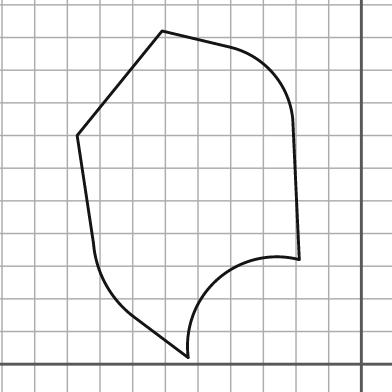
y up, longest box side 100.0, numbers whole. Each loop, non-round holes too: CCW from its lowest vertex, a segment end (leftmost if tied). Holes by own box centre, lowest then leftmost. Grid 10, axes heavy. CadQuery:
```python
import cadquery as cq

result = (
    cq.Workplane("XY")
    .moveTo(-53.0, 2.0)
    .threePointArc((-44.0, 26.0), (-19.0, 32.0))
    .lineTo(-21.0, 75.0)
    .threePointArc((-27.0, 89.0), (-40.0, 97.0))
    .lineTo(-61.0, 102.0)
    .lineTo(-87.0, 70.0)
    .lineTo(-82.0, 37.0)
    .threePointArc((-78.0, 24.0), (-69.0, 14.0))
    .close()
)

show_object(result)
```